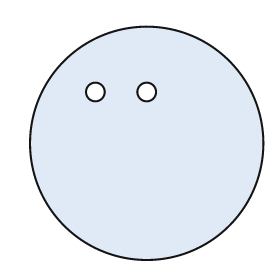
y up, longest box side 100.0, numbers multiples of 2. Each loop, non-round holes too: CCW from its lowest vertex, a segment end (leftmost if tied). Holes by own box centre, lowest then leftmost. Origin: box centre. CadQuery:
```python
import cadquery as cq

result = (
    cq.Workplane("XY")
    .moveTo(0.0, 0.0)
    .circle(50.0)
    .moveTo(-22.0, 22.0)
    .circle(4.0)
    .moveTo(0.0, 22.0)
    .circle(4.0)
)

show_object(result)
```